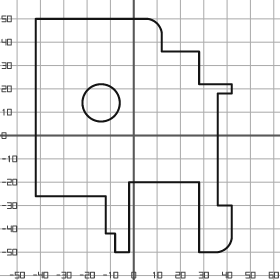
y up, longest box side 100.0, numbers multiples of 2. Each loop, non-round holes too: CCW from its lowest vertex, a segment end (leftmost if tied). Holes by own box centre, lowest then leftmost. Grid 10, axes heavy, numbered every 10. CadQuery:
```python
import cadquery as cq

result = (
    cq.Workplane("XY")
    .moveTo(-8.0, -50.0)
    .lineTo(-2.0, -50.0)
    .lineTo(-2.0, -20.0)
    .lineTo(28.0, -20.0)
    .lineTo(28.0, -50.0)
    .lineTo(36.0, -50.0)
    .threePointArc((40.0, -48.0), (42.0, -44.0))
    .lineTo(42.0, -30.0)
    .lineTo(36.0, -30.0)
    .lineTo(36.0, 18.0)
    .lineTo(42.0, 18.0)
    .lineTo(42.0, 22.0)
    .lineTo(28.0, 22.0)
    .lineTo(28.0, 36.0)
    .lineTo(12.0, 36.0)
    .lineTo(12.0, 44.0)
    .threePointArc((10.0, 48.0), (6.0, 50.0))
    .lineTo(-42.0, 50.0)
    .lineTo(-42.0, -26.0)
    .lineTo(-12.0, -26.0)
    .lineTo(-12.0, -42.0)
    .lineTo(-8.0, -42.0)
    .close()
    .moveTo(-14.0, 14.0)
    .circle(8.0)
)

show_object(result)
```